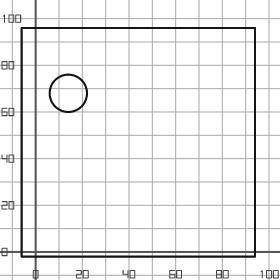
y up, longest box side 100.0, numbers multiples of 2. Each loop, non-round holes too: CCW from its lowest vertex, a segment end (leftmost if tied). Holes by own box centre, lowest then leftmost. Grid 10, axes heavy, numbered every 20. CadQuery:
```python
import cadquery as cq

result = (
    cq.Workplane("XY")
    .moveTo(-6.0, -2.0)
    .lineTo(94.0, -2.0)
    .lineTo(94.0, 96.0)
    .lineTo(-6.0, 96.0)
    .close()
    .moveTo(14.0, 68.0)
    .circle(8.0)
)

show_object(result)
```